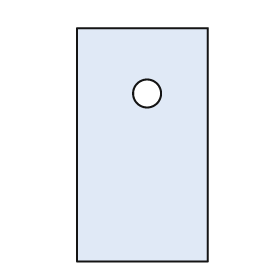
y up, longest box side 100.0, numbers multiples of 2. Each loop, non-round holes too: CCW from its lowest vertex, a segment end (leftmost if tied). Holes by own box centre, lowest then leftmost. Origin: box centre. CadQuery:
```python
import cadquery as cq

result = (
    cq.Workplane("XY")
    .moveTo(-28.0, -50.0)
    .lineTo(28.0, -50.0)
    .lineTo(28.0, 50.0)
    .lineTo(-28.0, 50.0)
    .close()
    .moveTo(2.0, 22.0)
    .circle(6.0)
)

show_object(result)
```